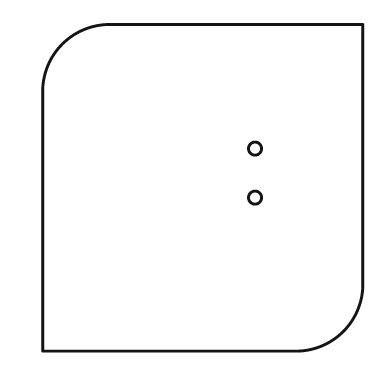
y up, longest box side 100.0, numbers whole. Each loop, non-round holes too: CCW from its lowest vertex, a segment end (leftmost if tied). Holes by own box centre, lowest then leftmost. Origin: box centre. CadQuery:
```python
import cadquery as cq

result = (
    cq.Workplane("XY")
    .moveTo(-49.0, -50.0)
    .lineTo(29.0, -50.0)
    .threePointArc((43.0, -44.0), (49.0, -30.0))
    .lineTo(49.0, 50.0)
    .lineTo(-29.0, 50.0)
    .threePointArc((-43.0, 44.0), (-49.0, 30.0))
    .close()
    .moveTo(16.0, -3.0)
    .circle(2.0)
    .moveTo(16.0, 12.0)
    .circle(2.0)
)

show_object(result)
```